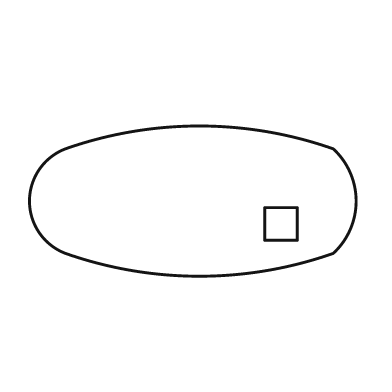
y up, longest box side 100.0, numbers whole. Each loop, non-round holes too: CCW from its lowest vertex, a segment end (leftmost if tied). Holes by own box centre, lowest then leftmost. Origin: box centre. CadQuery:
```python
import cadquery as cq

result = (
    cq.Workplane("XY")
    .moveTo(-39.0, -16.0)
    .threePointArc((2.0, -23.0), (43.0, -16.0))
    .threePointArc((50.0, 0.0), (43.0, 16.0))
    .threePointArc((2.0, 23.0), (-39.0, 16.0))
    .threePointArc((-50.0, 0.0), (-39.0, -16.0))
    .close()
    .moveTo(22.0, -12.0)
    .lineTo(32.0, -12.0)
    .lineTo(32.0, -2.0)
    .lineTo(22.0, -2.0)
    .close()
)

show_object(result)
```